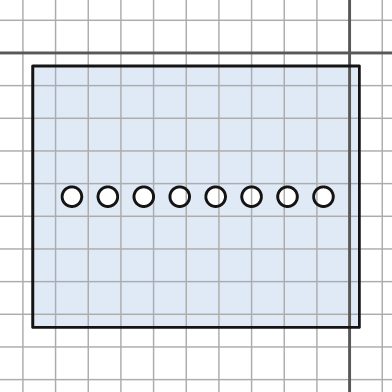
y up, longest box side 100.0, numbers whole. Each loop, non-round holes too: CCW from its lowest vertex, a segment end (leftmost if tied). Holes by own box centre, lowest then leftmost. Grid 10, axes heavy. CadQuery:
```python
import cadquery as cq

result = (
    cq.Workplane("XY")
    .moveTo(-97.0, -84.0)
    .lineTo(3.0, -84.0)
    .lineTo(3.0, -4.0)
    .lineTo(-97.0, -4.0)
    .close()
    .moveTo(-85.0, -44.0)
    .circle(3.0)
    .moveTo(-74.0, -44.0)
    .circle(3.0)
    .moveTo(-63.0, -44.0)
    .circle(3.0)
    .moveTo(-52.0, -44.0)
    .circle(3.0)
    .moveTo(-41.0, -44.0)
    .circle(3.0)
    .moveTo(-30.0, -44.0)
    .circle(3.0)
    .moveTo(-19.0, -44.0)
    .circle(3.0)
    .moveTo(-8.0, -44.0)
    .circle(3.0)
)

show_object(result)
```